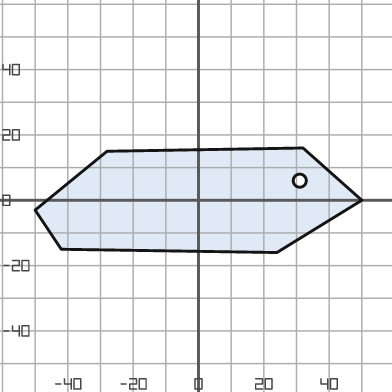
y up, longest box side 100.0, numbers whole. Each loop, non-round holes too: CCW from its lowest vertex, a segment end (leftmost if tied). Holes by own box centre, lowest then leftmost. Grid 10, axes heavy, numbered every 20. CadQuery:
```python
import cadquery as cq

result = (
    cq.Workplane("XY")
    .moveTo(24.0, -16.0)
    .lineTo(50.0, 0.0)
    .lineTo(32.0, 16.0)
    .lineTo(-28.0, 15.0)
    .lineTo(-50.0, -3.0)
    .lineTo(-42.0, -15.0)
    .close()
    .moveTo(31.0, 6.0)
    .circle(2.0)
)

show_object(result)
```